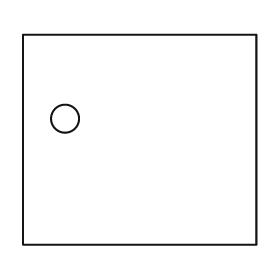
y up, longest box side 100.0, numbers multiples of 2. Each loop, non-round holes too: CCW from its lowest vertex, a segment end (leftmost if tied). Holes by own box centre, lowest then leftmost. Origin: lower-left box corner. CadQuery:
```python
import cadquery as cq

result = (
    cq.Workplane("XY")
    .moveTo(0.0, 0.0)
    .lineTo(100.0, 0.0)
    .lineTo(100.0, 90.0)
    .lineTo(0.0, 90.0)
    .close()
    .moveTo(18.0, 54.0)
    .circle(6.0)
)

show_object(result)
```